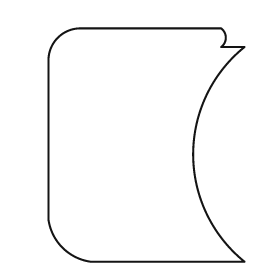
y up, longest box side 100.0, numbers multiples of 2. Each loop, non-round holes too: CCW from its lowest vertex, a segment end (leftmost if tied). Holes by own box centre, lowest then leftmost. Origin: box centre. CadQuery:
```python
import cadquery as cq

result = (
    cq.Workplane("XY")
    .moveTo(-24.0, -50.0)
    .lineTo(42.0, -50.0)
    .threePointArc((20.0, -4.0), (42.0, 42.0))
    .lineTo(32.0, 42.0)
    .threePointArc((34.0, 46.0), (32.0, 50.0))
    .lineTo(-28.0, 50.0)
    .threePointArc((-38.0, 46.0), (-42.0, 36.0))
    .lineTo(-42.0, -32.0)
    .threePointArc((-36.0, -44.0), (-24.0, -50.0))
    .close()
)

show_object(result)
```